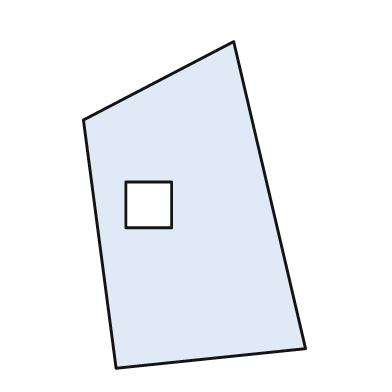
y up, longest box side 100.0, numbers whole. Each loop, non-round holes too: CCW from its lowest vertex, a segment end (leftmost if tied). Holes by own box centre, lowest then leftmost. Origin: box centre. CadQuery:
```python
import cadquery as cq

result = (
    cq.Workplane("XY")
    .moveTo(-24.0, -50.0)
    .lineTo(34.0, -44.0)
    .lineTo(12.0, 50.0)
    .lineTo(-34.0, 26.0)
    .close()
    .moveTo(-21.0, -7.0)
    .lineTo(-7.0, -7.0)
    .lineTo(-7.0, 7.0)
    .lineTo(-21.0, 7.0)
    .close()
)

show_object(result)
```